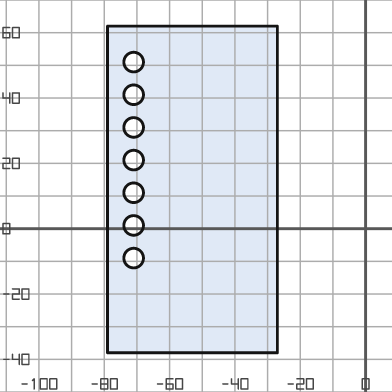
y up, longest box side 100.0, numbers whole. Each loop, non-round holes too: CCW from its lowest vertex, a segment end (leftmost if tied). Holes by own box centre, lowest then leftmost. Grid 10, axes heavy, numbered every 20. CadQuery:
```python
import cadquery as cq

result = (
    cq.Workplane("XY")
    .moveTo(-79.0, -38.0)
    .lineTo(-27.0, -38.0)
    .lineTo(-27.0, 62.0)
    .lineTo(-79.0, 62.0)
    .close()
    .moveTo(-71.0, -9.0)
    .circle(3.0)
    .moveTo(-71.0, 1.0)
    .circle(3.0)
    .moveTo(-71.0, 11.0)
    .circle(3.0)
    .moveTo(-71.0, 21.0)
    .circle(3.0)
    .moveTo(-71.0, 31.0)
    .circle(3.0)
    .moveTo(-71.0, 41.0)
    .circle(3.0)
    .moveTo(-71.0, 51.0)
    .circle(3.0)
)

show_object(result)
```